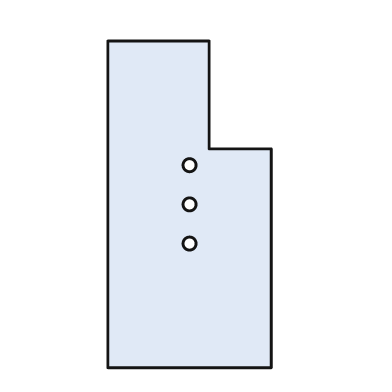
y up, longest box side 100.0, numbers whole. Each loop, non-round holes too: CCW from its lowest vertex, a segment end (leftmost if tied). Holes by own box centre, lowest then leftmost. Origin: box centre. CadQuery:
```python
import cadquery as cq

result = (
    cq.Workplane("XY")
    .moveTo(-25.0, -50.0)
    .lineTo(25.0, -50.0)
    .lineTo(25.0, 17.0)
    .lineTo(6.0, 17.0)
    .lineTo(6.0, 50.0)
    .lineTo(-25.0, 50.0)
    .close()
    .moveTo(0.0, -12.0)
    .circle(2.0)
    .moveTo(0.0, 0.0)
    .circle(2.0)
    .moveTo(0.0, 12.0)
    .circle(2.0)
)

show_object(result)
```